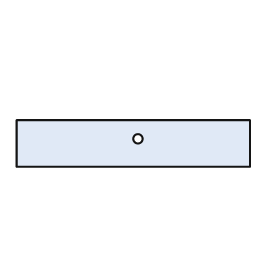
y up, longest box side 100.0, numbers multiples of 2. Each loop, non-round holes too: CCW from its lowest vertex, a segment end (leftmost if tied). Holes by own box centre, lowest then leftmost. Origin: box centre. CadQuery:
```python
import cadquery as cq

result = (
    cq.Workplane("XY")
    .moveTo(-50.0, -10.0)
    .lineTo(50.0, -10.0)
    .lineTo(50.0, 10.0)
    .lineTo(-50.0, 10.0)
    .close()
    .moveTo(2.0, 2.0)
    .circle(2.0)
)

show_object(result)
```